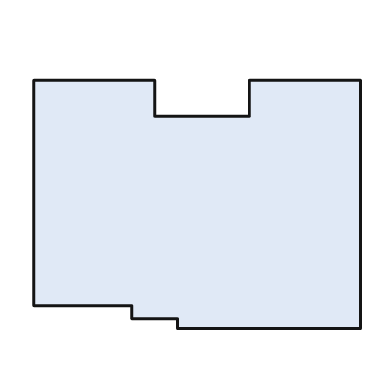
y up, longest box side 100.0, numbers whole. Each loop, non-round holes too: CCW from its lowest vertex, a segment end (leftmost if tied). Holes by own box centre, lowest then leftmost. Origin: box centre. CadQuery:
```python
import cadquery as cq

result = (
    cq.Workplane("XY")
    .moveTo(-6.0, -38.0)
    .lineTo(50.0, -38.0)
    .lineTo(50.0, 38.0)
    .lineTo(16.0, 38.0)
    .lineTo(16.0, 27.0)
    .lineTo(-13.0, 27.0)
    .lineTo(-13.0, 38.0)
    .lineTo(-50.0, 38.0)
    .lineTo(-50.0, -31.0)
    .lineTo(-20.0, -31.0)
    .lineTo(-20.0, -35.0)
    .lineTo(-6.0, -35.0)
    .close()
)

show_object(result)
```